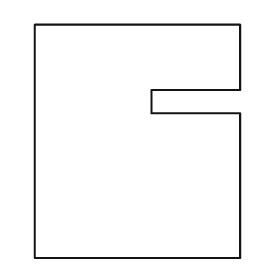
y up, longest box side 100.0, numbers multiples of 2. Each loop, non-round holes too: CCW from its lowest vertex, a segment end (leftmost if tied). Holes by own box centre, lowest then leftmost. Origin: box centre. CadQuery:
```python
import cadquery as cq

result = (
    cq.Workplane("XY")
    .moveTo(-44.0, -50.0)
    .lineTo(44.0, -50.0)
    .lineTo(44.0, 12.0)
    .lineTo(6.0, 12.0)
    .lineTo(6.0, 22.0)
    .lineTo(44.0, 22.0)
    .lineTo(44.0, 50.0)
    .lineTo(-44.0, 50.0)
    .close()
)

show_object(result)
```